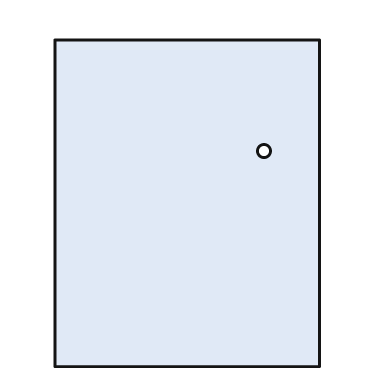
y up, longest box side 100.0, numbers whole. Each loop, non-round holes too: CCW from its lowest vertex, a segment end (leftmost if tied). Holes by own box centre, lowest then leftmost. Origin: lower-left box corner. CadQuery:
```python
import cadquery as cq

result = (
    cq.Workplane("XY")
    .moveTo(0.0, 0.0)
    .lineTo(81.0, 0.0)
    .lineTo(81.0, 100.0)
    .lineTo(0.0, 100.0)
    .close()
    .moveTo(64.0, 66.0)
    .circle(2.0)
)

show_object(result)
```